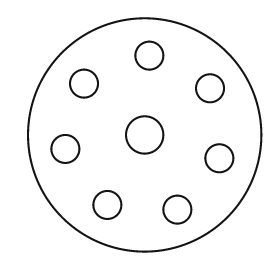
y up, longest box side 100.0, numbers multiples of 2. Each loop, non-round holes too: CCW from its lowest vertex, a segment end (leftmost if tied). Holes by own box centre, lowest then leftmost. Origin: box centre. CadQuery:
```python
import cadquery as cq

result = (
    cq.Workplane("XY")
    .moveTo(0.0, 0.0)
    .circle(50.0)
    .moveTo(14.0, -32.0)
    .circle(6.0)
    .moveTo(-16.0, -30.0)
    .circle(6.0)
    .moveTo(32.0, -10.0)
    .circle(6.0)
    .moveTo(-34.0, -6.0)
    .circle(6.0)
    .moveTo(0.0, 0.0)
    .circle(8.0)
    .moveTo(28.0, 20.0)
    .circle(6.0)
    .moveTo(-26.0, 22.0)
    .circle(6.0)
    .moveTo(2.0, 34.0)
    .circle(6.0)
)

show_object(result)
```